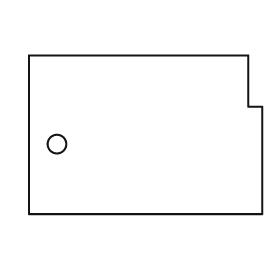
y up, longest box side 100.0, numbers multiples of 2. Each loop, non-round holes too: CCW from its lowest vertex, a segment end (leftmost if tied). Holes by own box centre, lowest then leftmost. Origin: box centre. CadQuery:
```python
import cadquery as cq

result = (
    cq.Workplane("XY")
    .moveTo(-50.0, -34.0)
    .lineTo(50.0, -34.0)
    .lineTo(50.0, 12.0)
    .lineTo(44.0, 12.0)
    .lineTo(44.0, 34.0)
    .lineTo(-50.0, 34.0)
    .close()
    .moveTo(-38.0, -4.0)
    .circle(4.0)
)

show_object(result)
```